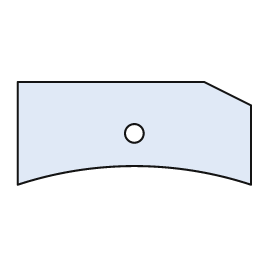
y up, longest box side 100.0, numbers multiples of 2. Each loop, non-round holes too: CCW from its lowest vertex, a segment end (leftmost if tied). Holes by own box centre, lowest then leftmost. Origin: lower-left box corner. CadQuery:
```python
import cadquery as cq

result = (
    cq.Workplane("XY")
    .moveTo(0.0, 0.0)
    .threePointArc((50.0, 8.0), (100.0, 0.0))
    .lineTo(100.0, 34.0)
    .lineTo(80.0, 44.0)
    .lineTo(0.0, 44.0)
    .close()
    .moveTo(50.0, 22.0)
    .circle(4.0)
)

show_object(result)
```